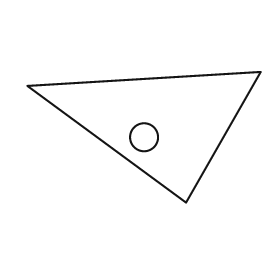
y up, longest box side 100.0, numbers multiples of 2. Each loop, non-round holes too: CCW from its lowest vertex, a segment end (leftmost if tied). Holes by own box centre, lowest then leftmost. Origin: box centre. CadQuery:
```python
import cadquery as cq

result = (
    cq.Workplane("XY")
    .moveTo(18.0, -28.0)
    .lineTo(50.0, 28.0)
    .lineTo(-50.0, 22.0)
    .close()
    .moveTo(0.0, 0.0)
    .circle(6.0)
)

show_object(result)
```